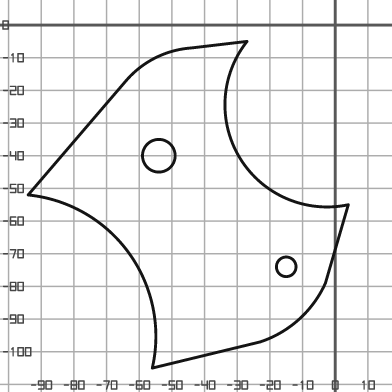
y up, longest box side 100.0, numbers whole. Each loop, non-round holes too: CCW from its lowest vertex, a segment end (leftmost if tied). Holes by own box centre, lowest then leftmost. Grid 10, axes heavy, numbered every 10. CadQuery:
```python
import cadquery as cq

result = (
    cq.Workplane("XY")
    .moveTo(-56.0, -105.0)
    .lineTo(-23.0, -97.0)
    .threePointArc((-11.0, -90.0), (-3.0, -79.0))
    .lineTo(4.0, -55.0)
    .threePointArc((-29.0, -41.0), (-27.0, -5.0))
    .lineTo(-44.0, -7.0)
    .threePointArc((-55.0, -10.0), (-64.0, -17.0))
    .lineTo(-94.0, -52.0)
    .threePointArc((-63.0, -70.0), (-56.0, -105.0))
    .close()
    .moveTo(-15.0, -74.0)
    .circle(3.0)
    .moveTo(-54.0, -40.0)
    .circle(5.0)
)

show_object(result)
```